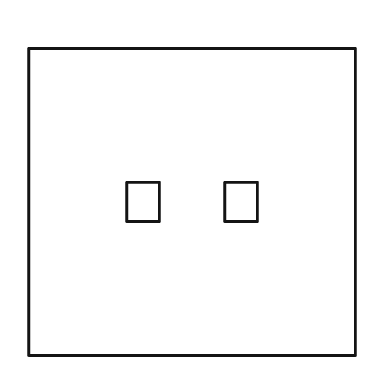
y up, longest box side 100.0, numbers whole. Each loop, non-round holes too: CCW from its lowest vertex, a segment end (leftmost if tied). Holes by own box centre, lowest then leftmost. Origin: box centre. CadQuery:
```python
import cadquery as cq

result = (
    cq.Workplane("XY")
    .moveTo(-50.0, -47.0)
    .lineTo(50.0, -47.0)
    .lineTo(50.0, 47.0)
    .lineTo(-50.0, 47.0)
    .close()
    .moveTo(-20.0, -6.0)
    .lineTo(-10.0, -6.0)
    .lineTo(-10.0, 6.0)
    .lineTo(-20.0, 6.0)
    .close()
    .moveTo(10.0, -6.0)
    .lineTo(20.0, -6.0)
    .lineTo(20.0, 6.0)
    .lineTo(10.0, 6.0)
    .close()
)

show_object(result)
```